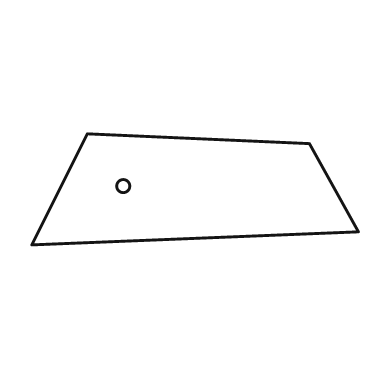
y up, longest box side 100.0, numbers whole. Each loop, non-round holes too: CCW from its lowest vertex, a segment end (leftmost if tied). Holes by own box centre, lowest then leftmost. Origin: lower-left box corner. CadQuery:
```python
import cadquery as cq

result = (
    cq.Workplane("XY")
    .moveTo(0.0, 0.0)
    .lineTo(100.0, 4.0)
    .lineTo(85.0, 31.0)
    .lineTo(17.0, 34.0)
    .close()
    .moveTo(28.0, 18.0)
    .circle(2.0)
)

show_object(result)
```